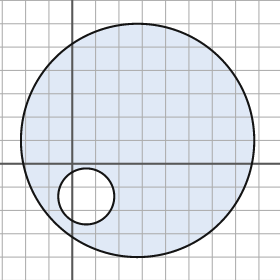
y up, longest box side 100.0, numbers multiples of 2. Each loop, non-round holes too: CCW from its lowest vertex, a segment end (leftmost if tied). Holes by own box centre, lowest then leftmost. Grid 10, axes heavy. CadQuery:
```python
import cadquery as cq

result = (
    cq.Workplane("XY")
    .moveTo(28.0, 10.0)
    .circle(50.0)
    .moveTo(6.0, -14.0)
    .circle(12.0)
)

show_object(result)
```